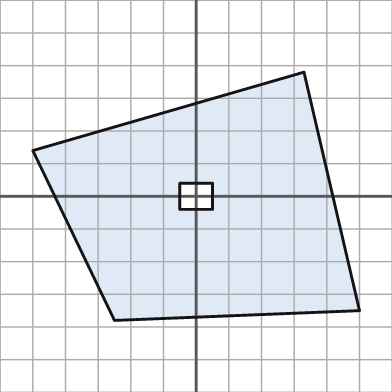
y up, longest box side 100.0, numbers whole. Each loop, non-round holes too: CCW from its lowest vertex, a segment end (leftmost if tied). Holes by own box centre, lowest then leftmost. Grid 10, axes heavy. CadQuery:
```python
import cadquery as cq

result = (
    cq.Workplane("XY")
    .moveTo(-25.0, -38.0)
    .lineTo(50.0, -35.0)
    .lineTo(33.0, 38.0)
    .lineTo(-50.0, 14.0)
    .close()
    .moveTo(-5.0, -4.0)
    .lineTo(5.0, -4.0)
    .lineTo(5.0, 4.0)
    .lineTo(-5.0, 4.0)
    .close()
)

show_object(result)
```